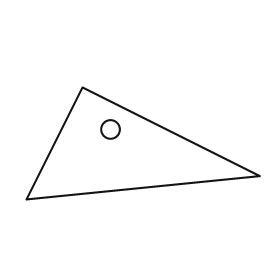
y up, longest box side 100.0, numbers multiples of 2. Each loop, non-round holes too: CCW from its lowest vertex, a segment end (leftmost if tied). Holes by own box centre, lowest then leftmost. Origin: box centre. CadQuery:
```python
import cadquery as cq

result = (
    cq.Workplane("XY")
    .moveTo(-50.0, -24.0)
    .lineTo(50.0, -14.0)
    .lineTo(-26.0, 24.0)
    .close()
    .moveTo(-14.0, 6.0)
    .circle(4.0)
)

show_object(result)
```